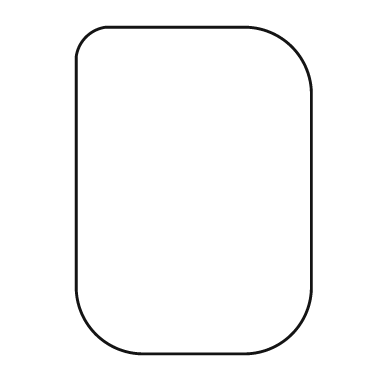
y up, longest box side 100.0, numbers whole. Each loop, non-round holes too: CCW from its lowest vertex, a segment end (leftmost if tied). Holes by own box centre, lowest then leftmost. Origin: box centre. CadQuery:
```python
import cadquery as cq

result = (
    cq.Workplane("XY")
    .moveTo(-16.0, -50.0)
    .lineTo(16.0, -50.0)
    .threePointArc((30.0, -44.0), (36.0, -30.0))
    .lineTo(36.0, 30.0)
    .threePointArc((30.0, 44.0), (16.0, 50.0))
    .lineTo(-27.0, 50.0)
    .threePointArc((-33.0, 47.0), (-36.0, 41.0))
    .lineTo(-36.0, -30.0)
    .threePointArc((-30.0, -44.0), (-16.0, -50.0))
    .close()
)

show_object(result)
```